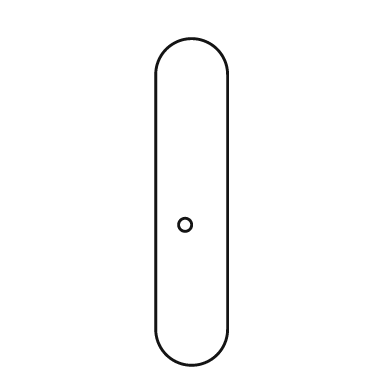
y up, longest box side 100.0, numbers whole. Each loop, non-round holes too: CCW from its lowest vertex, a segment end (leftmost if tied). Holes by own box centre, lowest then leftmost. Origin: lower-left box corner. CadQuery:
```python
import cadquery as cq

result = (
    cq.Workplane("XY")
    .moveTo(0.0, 11.0)
    .threePointArc((11.0, 0.0), (22.0, 11.0))
    .lineTo(22.0, 89.0)
    .threePointArc((11.0, 100.0), (0.0, 89.0))
    .close()
    .moveTo(9.0, 43.0)
    .circle(2.0)
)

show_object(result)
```